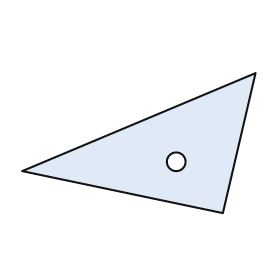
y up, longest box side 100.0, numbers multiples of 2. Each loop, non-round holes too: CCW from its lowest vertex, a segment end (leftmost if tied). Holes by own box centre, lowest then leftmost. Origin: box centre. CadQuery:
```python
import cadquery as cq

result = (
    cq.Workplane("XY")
    .moveTo(36.0, -30.0)
    .lineTo(50.0, 30.0)
    .lineTo(-50.0, -12.0)
    .close()
    .moveTo(16.0, -8.0)
    .circle(4.0)
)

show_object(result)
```